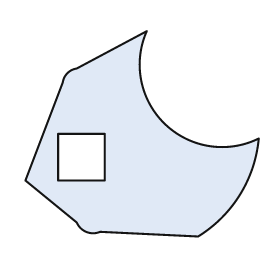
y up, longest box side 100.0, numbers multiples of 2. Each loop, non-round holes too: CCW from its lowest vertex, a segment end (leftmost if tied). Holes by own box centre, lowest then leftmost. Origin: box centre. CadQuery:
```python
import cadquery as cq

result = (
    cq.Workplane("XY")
    .moveTo(24.0, -44.0)
    .threePointArc((42.0, -26.0), (50.0, -2.0))
    .threePointArc((10.0, 4.0), (2.0, 44.0))
    .lineTo(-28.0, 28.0)
    .threePointArc((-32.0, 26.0), (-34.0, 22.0))
    .lineTo(-50.0, -20.0)
    .lineTo(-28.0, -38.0)
    .threePointArc((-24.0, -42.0), (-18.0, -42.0))
    .close()
    .moveTo(-36.0, -20.0)
    .lineTo(-16.0, -20.0)
    .lineTo(-16.0, 0.0)
    .lineTo(-36.0, 0.0)
    .close()
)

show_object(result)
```